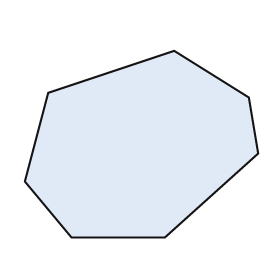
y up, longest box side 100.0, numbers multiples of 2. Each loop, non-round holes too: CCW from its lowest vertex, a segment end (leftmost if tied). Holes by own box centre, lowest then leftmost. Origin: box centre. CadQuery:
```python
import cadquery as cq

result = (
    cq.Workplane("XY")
    .moveTo(-30.0, -40.0)
    .lineTo(10.0, -40.0)
    .lineTo(50.0, -4.0)
    .lineTo(46.0, 20.0)
    .lineTo(14.0, 40.0)
    .lineTo(-40.0, 22.0)
    .lineTo(-50.0, -16.0)
    .close()
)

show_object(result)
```